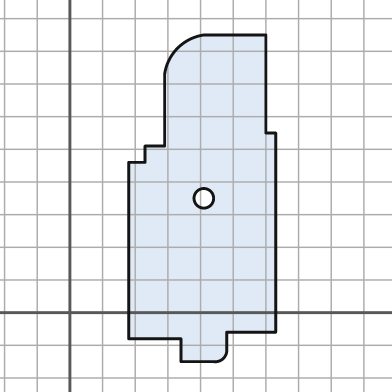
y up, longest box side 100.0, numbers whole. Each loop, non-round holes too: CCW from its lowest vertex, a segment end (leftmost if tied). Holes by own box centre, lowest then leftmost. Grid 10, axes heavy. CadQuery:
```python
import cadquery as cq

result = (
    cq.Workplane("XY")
    .moveTo(34.0, -15.0)
    .lineTo(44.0, -15.0)
    .threePointArc((47.0, -14.0), (48.0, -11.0))
    .lineTo(48.0, -6.0)
    .lineTo(63.0, -6.0)
    .lineTo(63.0, 55.0)
    .lineTo(60.0, 55.0)
    .lineTo(60.0, 85.0)
    .lineTo(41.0, 85.0)
    .threePointArc((33.0, 81.0), (29.0, 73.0))
    .lineTo(29.0, 51.0)
    .lineTo(23.0, 51.0)
    .lineTo(23.0, 46.0)
    .lineTo(18.0, 46.0)
    .lineTo(18.0, -8.0)
    .lineTo(34.0, -8.0)
    .close()
    .moveTo(41.0, 35.0)
    .circle(3.0)
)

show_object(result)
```